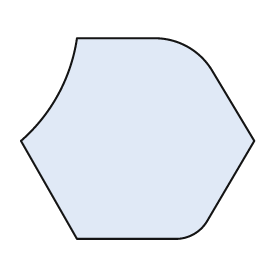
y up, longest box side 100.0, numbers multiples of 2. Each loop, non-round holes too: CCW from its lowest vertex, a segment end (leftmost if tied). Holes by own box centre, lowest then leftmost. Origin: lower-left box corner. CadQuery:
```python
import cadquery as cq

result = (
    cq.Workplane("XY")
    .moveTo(24.0, 0.0)
    .lineTo(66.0, 0.0)
    .threePointArc((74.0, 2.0), (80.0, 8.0))
    .lineTo(100.0, 42.0)
    .lineTo(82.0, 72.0)
    .threePointArc((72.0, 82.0), (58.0, 86.0))
    .lineTo(24.0, 86.0)
    .threePointArc((16.0, 62.0), (0.0, 42.0))
    .close()
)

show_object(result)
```